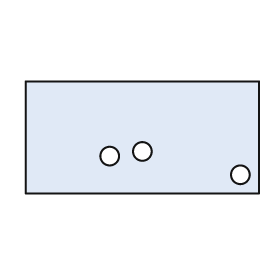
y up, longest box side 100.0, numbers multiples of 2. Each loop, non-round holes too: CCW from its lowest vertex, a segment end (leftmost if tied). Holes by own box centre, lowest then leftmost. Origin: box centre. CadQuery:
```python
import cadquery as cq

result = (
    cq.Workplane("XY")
    .moveTo(-50.0, -24.0)
    .lineTo(50.0, -24.0)
    .lineTo(50.0, 24.0)
    .lineTo(-50.0, 24.0)
    .close()
    .moveTo(42.0, -16.0)
    .circle(4.0)
    .moveTo(-14.0, -8.0)
    .circle(4.0)
    .moveTo(0.0, -6.0)
    .circle(4.0)
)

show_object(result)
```